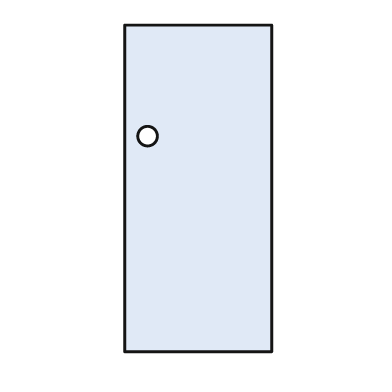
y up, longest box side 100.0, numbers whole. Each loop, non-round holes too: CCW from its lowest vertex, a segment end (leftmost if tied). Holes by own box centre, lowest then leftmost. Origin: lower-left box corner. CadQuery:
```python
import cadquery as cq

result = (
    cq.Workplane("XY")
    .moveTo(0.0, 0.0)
    .lineTo(45.0, 0.0)
    .lineTo(45.0, 100.0)
    .lineTo(0.0, 100.0)
    .close()
    .moveTo(7.0, 66.0)
    .circle(3.0)
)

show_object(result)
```